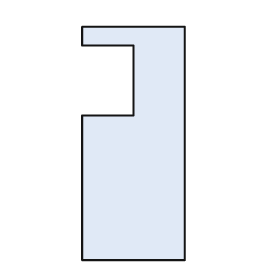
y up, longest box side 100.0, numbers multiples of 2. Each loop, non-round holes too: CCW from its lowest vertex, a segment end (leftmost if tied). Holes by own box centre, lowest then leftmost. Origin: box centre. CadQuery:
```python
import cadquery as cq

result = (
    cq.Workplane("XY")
    .moveTo(-22.0, -50.0)
    .lineTo(22.0, -50.0)
    .lineTo(22.0, 50.0)
    .lineTo(-22.0, 50.0)
    .lineTo(-22.0, 42.0)
    .lineTo(0.0, 42.0)
    .lineTo(0.0, 12.0)
    .lineTo(-22.0, 12.0)
    .close()
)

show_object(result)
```